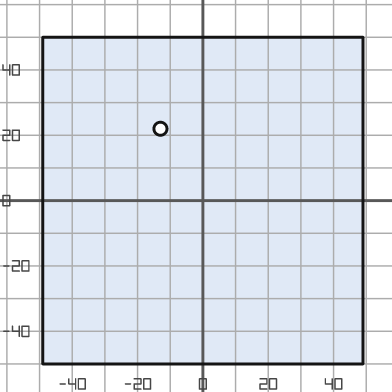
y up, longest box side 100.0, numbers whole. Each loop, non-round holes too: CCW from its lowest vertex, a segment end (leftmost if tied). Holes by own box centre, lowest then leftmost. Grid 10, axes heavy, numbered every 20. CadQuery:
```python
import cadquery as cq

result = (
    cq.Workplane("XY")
    .moveTo(-49.0, -50.0)
    .lineTo(49.0, -50.0)
    .lineTo(49.0, 50.0)
    .lineTo(-49.0, 50.0)
    .close()
    .moveTo(-13.0, 22.0)
    .circle(2.0)
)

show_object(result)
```